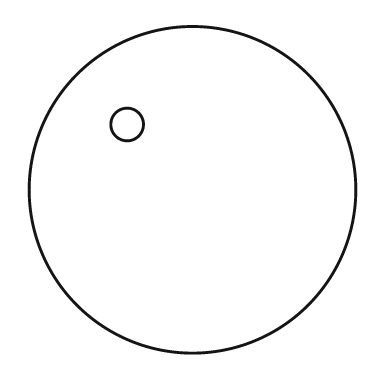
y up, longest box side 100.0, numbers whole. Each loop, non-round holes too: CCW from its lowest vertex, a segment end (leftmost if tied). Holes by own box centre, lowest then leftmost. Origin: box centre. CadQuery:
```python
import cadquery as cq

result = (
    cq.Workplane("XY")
    .moveTo(0.0, 0.0)
    .circle(50.0)
    .moveTo(-20.0, 20.0)
    .circle(5.0)
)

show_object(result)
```